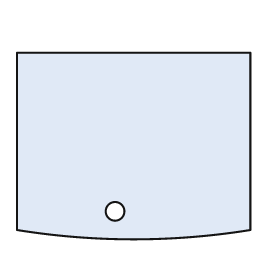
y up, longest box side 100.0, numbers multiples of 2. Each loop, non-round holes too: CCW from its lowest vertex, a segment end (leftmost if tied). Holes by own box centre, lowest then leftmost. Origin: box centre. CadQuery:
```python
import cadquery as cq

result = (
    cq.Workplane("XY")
    .moveTo(-50.0, -36.0)
    .threePointArc((0.0, -40.0), (50.0, -36.0))
    .lineTo(50.0, 40.0)
    .lineTo(-50.0, 40.0)
    .close()
    .moveTo(-8.0, -28.0)
    .circle(4.0)
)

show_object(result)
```